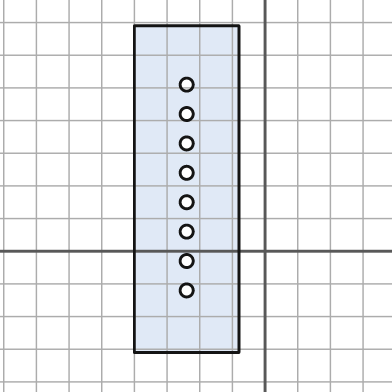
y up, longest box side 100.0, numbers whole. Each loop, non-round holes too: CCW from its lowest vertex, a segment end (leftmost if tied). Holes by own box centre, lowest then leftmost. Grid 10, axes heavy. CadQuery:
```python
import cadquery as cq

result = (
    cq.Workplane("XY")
    .moveTo(-40.0, -31.0)
    .lineTo(-8.0, -31.0)
    .lineTo(-8.0, 69.0)
    .lineTo(-40.0, 69.0)
    .close()
    .moveTo(-24.0, -12.0)
    .circle(2.0)
    .moveTo(-24.0, -3.0)
    .circle(2.0)
    .moveTo(-24.0, 6.0)
    .circle(2.0)
    .moveTo(-24.0, 15.0)
    .circle(2.0)
    .moveTo(-24.0, 24.0)
    .circle(2.0)
    .moveTo(-24.0, 33.0)
    .circle(2.0)
    .moveTo(-24.0, 42.0)
    .circle(2.0)
    .moveTo(-24.0, 51.0)
    .circle(2.0)
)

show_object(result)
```